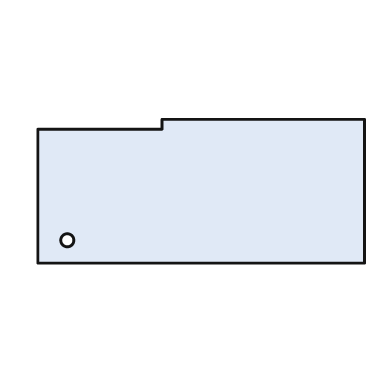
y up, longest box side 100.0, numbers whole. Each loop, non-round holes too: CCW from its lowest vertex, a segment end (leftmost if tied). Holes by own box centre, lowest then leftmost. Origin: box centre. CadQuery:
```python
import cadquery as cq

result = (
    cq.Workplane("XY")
    .moveTo(-50.0, -22.0)
    .lineTo(50.0, -22.0)
    .lineTo(50.0, 22.0)
    .lineTo(-12.0, 22.0)
    .lineTo(-12.0, 19.0)
    .lineTo(-50.0, 19.0)
    .close()
    .moveTo(-41.0, -15.0)
    .circle(2.0)
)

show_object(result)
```